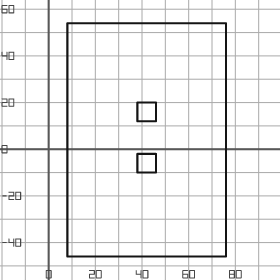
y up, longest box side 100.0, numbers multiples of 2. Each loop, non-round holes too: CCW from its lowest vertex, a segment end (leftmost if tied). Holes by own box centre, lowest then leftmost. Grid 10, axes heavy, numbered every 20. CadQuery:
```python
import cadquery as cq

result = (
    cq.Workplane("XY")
    .moveTo(8.0, -46.0)
    .lineTo(76.0, -46.0)
    .lineTo(76.0, 54.0)
    .lineTo(8.0, 54.0)
    .close()
    .moveTo(38.0, -10.0)
    .lineTo(46.0, -10.0)
    .lineTo(46.0, -2.0)
    .lineTo(38.0, -2.0)
    .close()
    .moveTo(38.0, 12.0)
    .lineTo(46.0, 12.0)
    .lineTo(46.0, 20.0)
    .lineTo(38.0, 20.0)
    .close()
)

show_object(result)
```